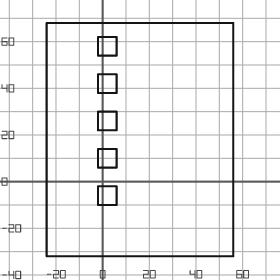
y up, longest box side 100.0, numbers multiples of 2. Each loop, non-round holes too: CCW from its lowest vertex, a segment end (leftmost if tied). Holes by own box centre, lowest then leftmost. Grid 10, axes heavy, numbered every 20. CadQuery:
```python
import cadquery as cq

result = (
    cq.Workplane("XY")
    .moveTo(-24.0, -32.0)
    .lineTo(56.0, -32.0)
    .lineTo(56.0, 68.0)
    .lineTo(-24.0, 68.0)
    .close()
    .moveTo(-2.0, -10.0)
    .lineTo(6.0, -10.0)
    .lineTo(6.0, -2.0)
    .lineTo(-2.0, -2.0)
    .close()
    .moveTo(-2.0, 6.0)
    .lineTo(6.0, 6.0)
    .lineTo(6.0, 14.0)
    .lineTo(-2.0, 14.0)
    .close()
    .moveTo(-2.0, 22.0)
    .lineTo(6.0, 22.0)
    .lineTo(6.0, 30.0)
    .lineTo(-2.0, 30.0)
    .close()
    .moveTo(-2.0, 38.0)
    .lineTo(6.0, 38.0)
    .lineTo(6.0, 46.0)
    .lineTo(-2.0, 46.0)
    .close()
    .moveTo(-2.0, 54.0)
    .lineTo(6.0, 54.0)
    .lineTo(6.0, 62.0)
    .lineTo(-2.0, 62.0)
    .close()
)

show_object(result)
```